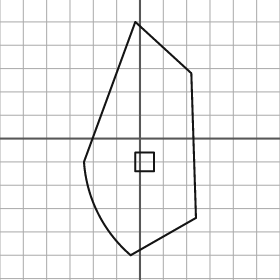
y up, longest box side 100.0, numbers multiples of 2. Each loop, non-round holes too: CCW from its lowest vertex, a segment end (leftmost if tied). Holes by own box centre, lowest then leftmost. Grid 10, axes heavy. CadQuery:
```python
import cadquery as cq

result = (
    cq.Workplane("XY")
    .moveTo(-4.0, -50.0)
    .lineTo(24.0, -34.0)
    .lineTo(22.0, 28.0)
    .lineTo(-2.0, 50.0)
    .lineTo(-24.0, -10.0)
    .threePointArc((-18.0, -32.0), (-4.0, -50.0))
    .close()
    .moveTo(-2.0, -14.0)
    .lineTo(6.0, -14.0)
    .lineTo(6.0, -6.0)
    .lineTo(-2.0, -6.0)
    .close()
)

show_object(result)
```